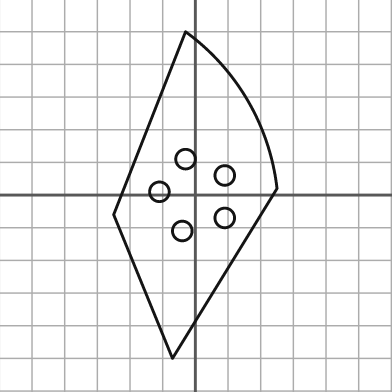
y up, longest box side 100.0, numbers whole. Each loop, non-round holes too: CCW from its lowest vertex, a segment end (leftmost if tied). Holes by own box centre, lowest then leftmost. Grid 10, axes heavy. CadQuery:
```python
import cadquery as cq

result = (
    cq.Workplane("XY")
    .moveTo(-7.0, -50.0)
    .lineTo(25.0, 2.0)
    .threePointArc((16.0, 29.0), (-3.0, 50.0))
    .lineTo(-25.0, -6.0)
    .close()
    .moveTo(-4.0, -11.0)
    .circle(3.0)
    .moveTo(9.0, -7.0)
    .circle(3.0)
    .moveTo(-11.0, 1.0)
    .circle(3.0)
    .moveTo(9.0, 6.0)
    .circle(3.0)
    .moveTo(-3.0, 11.0)
    .circle(3.0)
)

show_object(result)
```